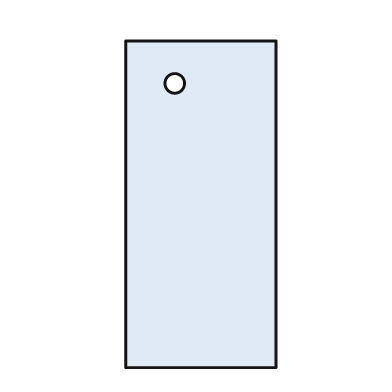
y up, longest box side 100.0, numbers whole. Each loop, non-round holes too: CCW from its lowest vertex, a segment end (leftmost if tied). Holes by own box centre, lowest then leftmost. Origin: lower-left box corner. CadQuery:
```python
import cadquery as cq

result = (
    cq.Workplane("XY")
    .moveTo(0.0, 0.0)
    .lineTo(46.0, 0.0)
    .lineTo(46.0, 100.0)
    .lineTo(0.0, 100.0)
    .close()
    .moveTo(15.0, 87.0)
    .circle(3.0)
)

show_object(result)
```